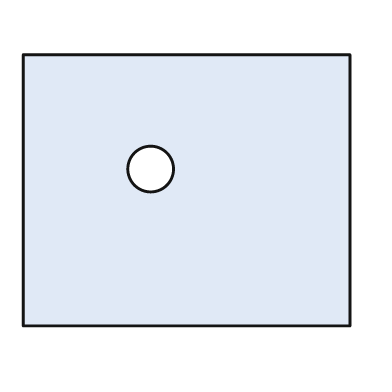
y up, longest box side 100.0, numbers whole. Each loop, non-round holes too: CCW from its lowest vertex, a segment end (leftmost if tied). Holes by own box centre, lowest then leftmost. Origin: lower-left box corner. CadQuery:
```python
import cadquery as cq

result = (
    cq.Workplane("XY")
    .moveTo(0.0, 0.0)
    .lineTo(100.0, 0.0)
    .lineTo(100.0, 83.0)
    .lineTo(0.0, 83.0)
    .close()
    .moveTo(39.0, 48.0)
    .circle(7.0)
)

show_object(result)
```